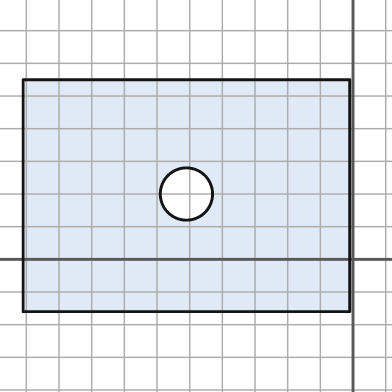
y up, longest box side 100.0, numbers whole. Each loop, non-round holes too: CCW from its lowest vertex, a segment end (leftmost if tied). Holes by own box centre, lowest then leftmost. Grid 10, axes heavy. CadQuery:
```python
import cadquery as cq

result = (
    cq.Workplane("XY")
    .moveTo(-101.0, -16.0)
    .lineTo(-1.0, -16.0)
    .lineTo(-1.0, 55.0)
    .lineTo(-101.0, 55.0)
    .close()
    .moveTo(-51.0, 20.0)
    .circle(8.0)
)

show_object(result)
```